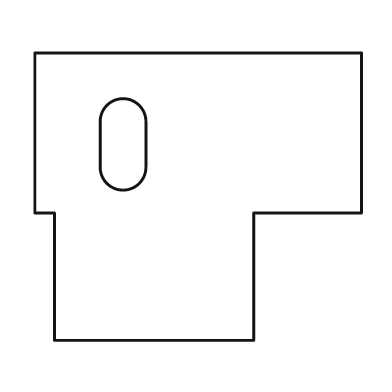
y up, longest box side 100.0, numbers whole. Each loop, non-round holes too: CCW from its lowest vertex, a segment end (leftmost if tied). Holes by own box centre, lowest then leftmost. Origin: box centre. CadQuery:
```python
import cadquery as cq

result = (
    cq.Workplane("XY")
    .moveTo(-44.0, -44.0)
    .lineTo(17.0, -44.0)
    .lineTo(17.0, -5.0)
    .lineTo(50.0, -5.0)
    .lineTo(50.0, 44.0)
    .lineTo(-50.0, 44.0)
    .lineTo(-50.0, -5.0)
    .lineTo(-44.0, -5.0)
    .close()
    .moveTo(-30.0, 9.0)
    .threePointArc((-23.0, 2.0), (-16.0, 9.0))
    .lineTo(-16.0, 23.0)
    .threePointArc((-23.0, 30.0), (-30.0, 23.0))
    .close()
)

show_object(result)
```